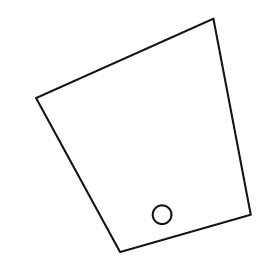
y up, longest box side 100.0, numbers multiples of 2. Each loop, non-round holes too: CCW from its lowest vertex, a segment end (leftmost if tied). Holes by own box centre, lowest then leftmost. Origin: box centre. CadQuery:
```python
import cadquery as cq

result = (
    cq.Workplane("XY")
    .moveTo(-10.0, -50.0)
    .lineTo(46.0, -34.0)
    .lineTo(30.0, 50.0)
    .lineTo(-46.0, 16.0)
    .close()
    .moveTo(8.0, -34.0)
    .circle(4.0)
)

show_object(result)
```